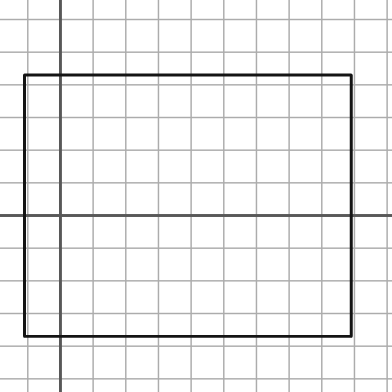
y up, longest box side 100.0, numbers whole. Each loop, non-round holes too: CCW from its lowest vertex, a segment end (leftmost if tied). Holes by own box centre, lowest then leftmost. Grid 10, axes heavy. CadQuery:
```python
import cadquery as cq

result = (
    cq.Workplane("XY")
    .moveTo(-11.0, -37.0)
    .lineTo(89.0, -37.0)
    .lineTo(89.0, 43.0)
    .lineTo(-11.0, 43.0)
    .close()
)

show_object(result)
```